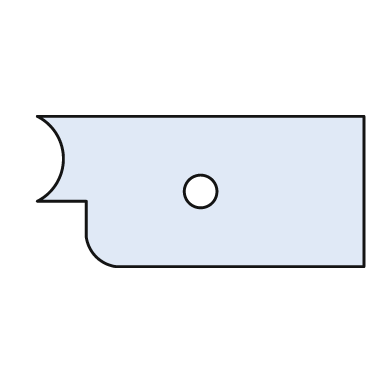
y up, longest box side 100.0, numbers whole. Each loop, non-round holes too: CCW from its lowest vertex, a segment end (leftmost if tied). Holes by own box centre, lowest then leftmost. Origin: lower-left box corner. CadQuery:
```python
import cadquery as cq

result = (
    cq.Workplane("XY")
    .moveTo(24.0, 0.0)
    .lineTo(100.0, 0.0)
    .lineTo(100.0, 46.0)
    .lineTo(0.0, 46.0)
    .threePointArc((8.0, 33.0), (0.0, 20.0))
    .lineTo(15.0, 20.0)
    .lineTo(15.0, 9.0)
    .threePointArc((18.0, 3.0), (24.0, 0.0))
    .close()
    .moveTo(50.0, 23.0)
    .circle(5.0)
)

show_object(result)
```